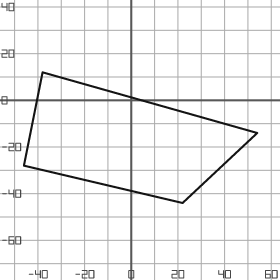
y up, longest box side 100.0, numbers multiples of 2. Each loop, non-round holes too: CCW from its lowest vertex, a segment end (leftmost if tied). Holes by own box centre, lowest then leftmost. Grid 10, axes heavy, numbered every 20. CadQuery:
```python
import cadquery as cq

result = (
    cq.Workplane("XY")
    .moveTo(22.0, -44.0)
    .lineTo(54.0, -14.0)
    .lineTo(-38.0, 12.0)
    .lineTo(-46.0, -28.0)
    .close()
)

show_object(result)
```